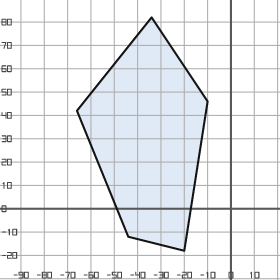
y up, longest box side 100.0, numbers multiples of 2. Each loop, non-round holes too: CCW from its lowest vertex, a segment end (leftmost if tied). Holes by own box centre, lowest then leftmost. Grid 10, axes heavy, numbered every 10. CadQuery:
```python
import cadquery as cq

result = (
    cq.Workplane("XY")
    .moveTo(-20.0, -18.0)
    .lineTo(-10.0, 46.0)
    .lineTo(-34.0, 82.0)
    .lineTo(-66.0, 42.0)
    .lineTo(-44.0, -12.0)
    .close()
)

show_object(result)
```